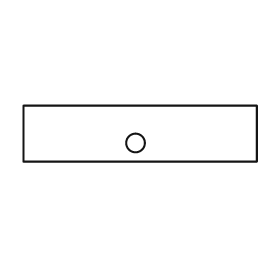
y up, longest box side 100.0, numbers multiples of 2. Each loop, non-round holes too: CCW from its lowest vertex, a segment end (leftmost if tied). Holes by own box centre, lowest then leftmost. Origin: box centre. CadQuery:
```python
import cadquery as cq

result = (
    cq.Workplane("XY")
    .moveTo(-50.0, -12.0)
    .lineTo(50.0, -12.0)
    .lineTo(50.0, 12.0)
    .lineTo(-50.0, 12.0)
    .close()
    .moveTo(-2.0, -4.0)
    .circle(4.0)
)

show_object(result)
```